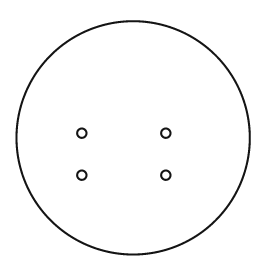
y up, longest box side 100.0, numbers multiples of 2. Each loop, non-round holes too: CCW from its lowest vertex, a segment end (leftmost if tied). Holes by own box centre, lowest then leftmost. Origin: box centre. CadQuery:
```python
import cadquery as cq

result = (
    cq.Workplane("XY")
    .moveTo(0.0, 0.0)
    .circle(50.0)
    .moveTo(-22.0, -16.0)
    .circle(2.0)
    .moveTo(14.0, -16.0)
    .circle(2.0)
    .moveTo(-22.0, 2.0)
    .circle(2.0)
    .moveTo(14.0, 2.0)
    .circle(2.0)
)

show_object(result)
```